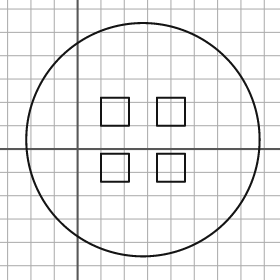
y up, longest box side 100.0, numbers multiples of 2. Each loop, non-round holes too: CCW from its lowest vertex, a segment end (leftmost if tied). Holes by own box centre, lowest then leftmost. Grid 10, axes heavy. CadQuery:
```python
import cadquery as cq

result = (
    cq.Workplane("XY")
    .moveTo(28.0, 4.0)
    .circle(50.0)
    .moveTo(10.0, -14.0)
    .lineTo(22.0, -14.0)
    .lineTo(22.0, -2.0)
    .lineTo(10.0, -2.0)
    .close()
    .moveTo(34.0, -14.0)
    .lineTo(46.0, -14.0)
    .lineTo(46.0, -2.0)
    .lineTo(34.0, -2.0)
    .close()
    .moveTo(10.0, 10.0)
    .lineTo(22.0, 10.0)
    .lineTo(22.0, 22.0)
    .lineTo(10.0, 22.0)
    .close()
    .moveTo(34.0, 10.0)
    .lineTo(46.0, 10.0)
    .lineTo(46.0, 22.0)
    .lineTo(34.0, 22.0)
    .close()
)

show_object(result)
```